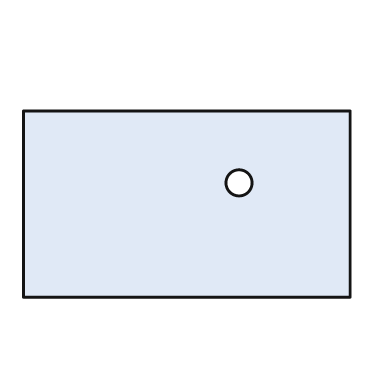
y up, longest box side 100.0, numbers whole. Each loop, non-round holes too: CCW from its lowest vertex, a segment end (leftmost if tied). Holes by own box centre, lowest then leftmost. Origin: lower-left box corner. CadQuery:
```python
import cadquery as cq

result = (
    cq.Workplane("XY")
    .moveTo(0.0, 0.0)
    .lineTo(100.0, 0.0)
    .lineTo(100.0, 57.0)
    .lineTo(0.0, 57.0)
    .close()
    .moveTo(66.0, 35.0)
    .circle(4.0)
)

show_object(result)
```